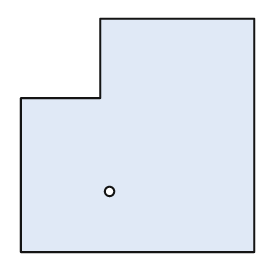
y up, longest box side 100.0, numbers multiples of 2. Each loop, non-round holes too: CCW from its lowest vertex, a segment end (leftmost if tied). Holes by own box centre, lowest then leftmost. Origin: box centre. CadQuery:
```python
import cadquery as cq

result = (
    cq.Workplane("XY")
    .moveTo(-50.0, -50.0)
    .lineTo(50.0, -50.0)
    .lineTo(50.0, 50.0)
    .lineTo(-16.0, 50.0)
    .lineTo(-16.0, 16.0)
    .lineTo(-50.0, 16.0)
    .close()
    .moveTo(-12.0, -24.0)
    .circle(2.0)
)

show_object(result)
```